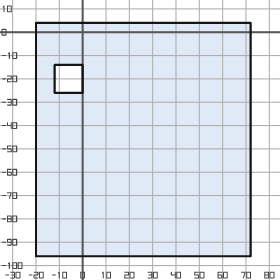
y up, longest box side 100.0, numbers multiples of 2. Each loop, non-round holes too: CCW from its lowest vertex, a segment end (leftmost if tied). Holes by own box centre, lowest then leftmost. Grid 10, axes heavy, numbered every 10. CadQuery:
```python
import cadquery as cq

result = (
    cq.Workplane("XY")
    .moveTo(-20.0, -96.0)
    .lineTo(72.0, -96.0)
    .lineTo(72.0, 4.0)
    .lineTo(-20.0, 4.0)
    .close()
    .moveTo(-12.0, -26.0)
    .lineTo(0.0, -26.0)
    .lineTo(0.0, -14.0)
    .lineTo(-12.0, -14.0)
    .close()
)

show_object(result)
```